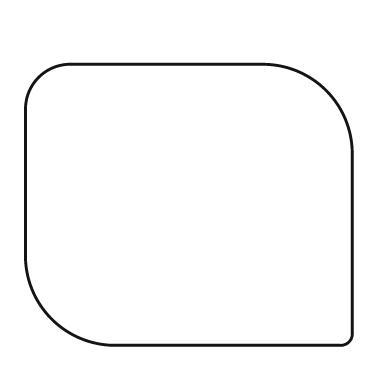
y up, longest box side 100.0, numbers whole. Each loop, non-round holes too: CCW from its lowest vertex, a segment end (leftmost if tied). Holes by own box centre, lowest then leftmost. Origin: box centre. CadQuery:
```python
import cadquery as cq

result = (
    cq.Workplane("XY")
    .moveTo(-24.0, -43.0)
    .lineTo(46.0, -43.0)
    .threePointArc((49.0, -42.0), (50.0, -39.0))
    .lineTo(50.0, 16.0)
    .threePointArc((42.0, 35.0), (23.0, 43.0))
    .lineTo(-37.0, 43.0)
    .threePointArc((-46.0, 39.0), (-50.0, 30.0))
    .lineTo(-50.0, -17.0)
    .threePointArc((-42.0, -35.0), (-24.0, -43.0))
    .close()
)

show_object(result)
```